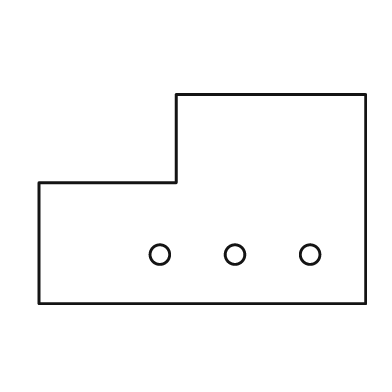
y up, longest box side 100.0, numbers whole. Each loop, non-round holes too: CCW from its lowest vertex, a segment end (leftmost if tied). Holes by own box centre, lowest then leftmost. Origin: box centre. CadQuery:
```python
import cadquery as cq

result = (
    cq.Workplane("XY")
    .moveTo(-50.0, -32.0)
    .lineTo(50.0, -32.0)
    .lineTo(50.0, 32.0)
    .lineTo(-8.0, 32.0)
    .lineTo(-8.0, 5.0)
    .lineTo(-50.0, 5.0)
    .close()
    .moveTo(-13.0, -17.0)
    .circle(3.0)
    .moveTo(10.0, -17.0)
    .circle(3.0)
    .moveTo(33.0, -17.0)
    .circle(3.0)
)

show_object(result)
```